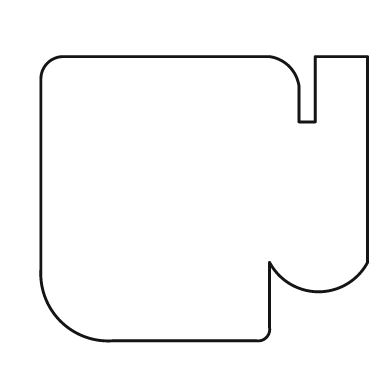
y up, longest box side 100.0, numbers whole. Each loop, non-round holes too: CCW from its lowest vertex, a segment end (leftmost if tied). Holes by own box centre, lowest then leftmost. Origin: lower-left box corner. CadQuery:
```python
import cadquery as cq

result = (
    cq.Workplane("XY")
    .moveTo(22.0, 0.0)
    .lineTo(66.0, 0.0)
    .threePointArc((69.0, 1.0), (70.0, 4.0))
    .lineTo(70.0, 24.0)
    .threePointArc((85.0, 15.0), (100.0, 24.0))
    .lineTo(100.0, 87.0)
    .lineTo(84.0, 87.0)
    .lineTo(84.0, 67.0)
    .lineTo(79.0, 67.0)
    .lineTo(79.0, 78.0)
    .threePointArc((76.0, 84.0), (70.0, 87.0))
    .lineTo(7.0, 87.0)
    .threePointArc((2.0, 85.0), (0.0, 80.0))
    .lineTo(0.0, 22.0)
    .threePointArc((6.0, 6.0), (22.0, 0.0))
    .close()
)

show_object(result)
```